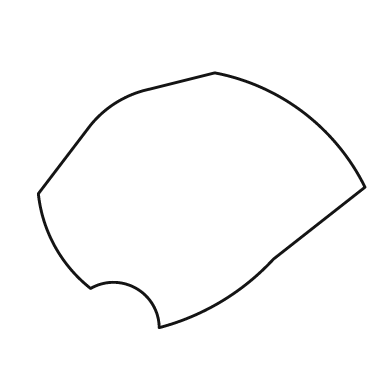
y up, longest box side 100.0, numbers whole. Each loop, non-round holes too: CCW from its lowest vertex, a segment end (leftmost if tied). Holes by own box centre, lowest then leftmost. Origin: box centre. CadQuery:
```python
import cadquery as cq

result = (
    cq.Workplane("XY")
    .moveTo(-13.0, -39.0)
    .threePointArc((6.0, -31.0), (22.0, -18.0))
    .lineTo(50.0, 4.0)
    .threePointArc((31.0, 27.0), (4.0, 39.0))
    .lineTo(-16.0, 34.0)
    .threePointArc((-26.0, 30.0), (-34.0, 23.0))
    .lineTo(-50.0, 2.0)
    .threePointArc((-45.0, -14.0), (-34.0, -27.0))
    .threePointArc((-20.0, -27.0), (-13.0, -39.0))
    .close()
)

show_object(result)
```